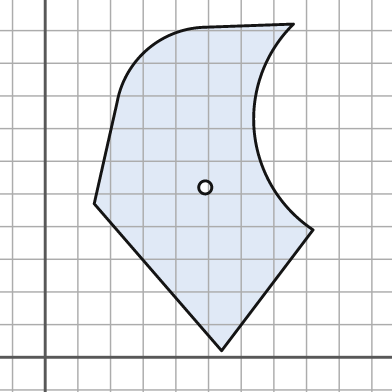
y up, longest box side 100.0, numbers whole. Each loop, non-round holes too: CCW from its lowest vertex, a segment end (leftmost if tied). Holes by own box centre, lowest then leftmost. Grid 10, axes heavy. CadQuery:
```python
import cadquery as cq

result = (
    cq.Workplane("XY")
    .moveTo(54.0, 2.0)
    .lineTo(82.0, 39.0)
    .threePointArc((64.0, 69.0), (76.0, 102.0))
    .lineTo(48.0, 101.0)
    .threePointArc((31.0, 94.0), (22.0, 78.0))
    .lineTo(15.0, 47.0)
    .close()
    .moveTo(49.0, 52.0)
    .circle(2.0)
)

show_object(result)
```